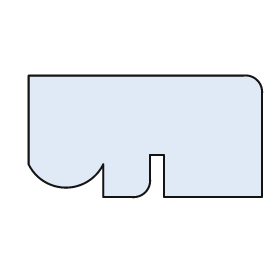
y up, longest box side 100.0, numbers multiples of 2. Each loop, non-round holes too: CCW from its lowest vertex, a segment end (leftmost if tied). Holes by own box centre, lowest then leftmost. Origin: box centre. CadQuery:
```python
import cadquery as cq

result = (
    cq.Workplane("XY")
    .moveTo(-18.0, -26.0)
    .lineTo(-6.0, -26.0)
    .threePointArc((0.0, -24.0), (2.0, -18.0))
    .lineTo(2.0, -8.0)
    .lineTo(8.0, -8.0)
    .lineTo(8.0, -26.0)
    .lineTo(50.0, -26.0)
    .lineTo(50.0, 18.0)
    .threePointArc((48.0, 24.0), (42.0, 26.0))
    .lineTo(-50.0, 26.0)
    .lineTo(-50.0, -12.0)
    .threePointArc((-34.0, -22.0), (-18.0, -12.0))
    .close()
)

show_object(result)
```